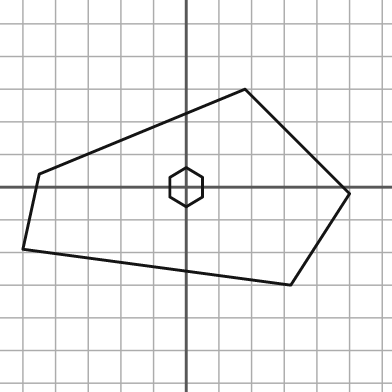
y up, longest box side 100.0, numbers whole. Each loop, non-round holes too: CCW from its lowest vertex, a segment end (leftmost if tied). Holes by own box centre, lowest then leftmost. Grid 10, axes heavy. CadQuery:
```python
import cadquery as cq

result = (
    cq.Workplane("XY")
    .moveTo(32.0, -30.0)
    .lineTo(50.0, -2.0)
    .lineTo(18.0, 30.0)
    .lineTo(-45.0, 4.0)
    .lineTo(-50.0, -19.0)
    .close()
    .moveTo(0.0, -6.0)
    .lineTo(5.0, -3.0)
    .lineTo(5.0, 3.0)
    .lineTo(0.0, 6.0)
    .lineTo(-5.0, 3.0)
    .lineTo(-5.0, -3.0)
    .close()
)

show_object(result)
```